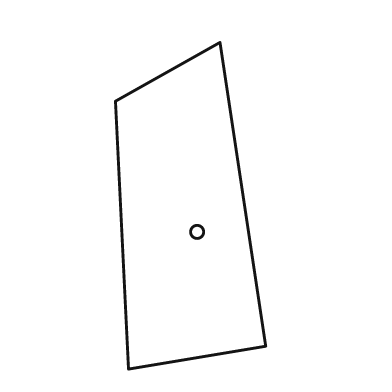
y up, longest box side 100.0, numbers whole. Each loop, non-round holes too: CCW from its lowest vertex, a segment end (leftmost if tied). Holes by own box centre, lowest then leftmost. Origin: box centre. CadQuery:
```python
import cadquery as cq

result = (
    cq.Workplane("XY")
    .moveTo(-19.0, -50.0)
    .lineTo(23.0, -43.0)
    .lineTo(9.0, 50.0)
    .lineTo(-23.0, 32.0)
    .close()
    .moveTo(2.0, -8.0)
    .circle(2.0)
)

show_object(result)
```